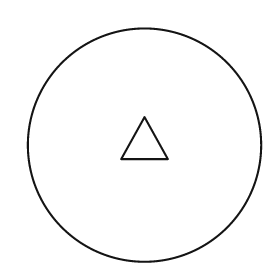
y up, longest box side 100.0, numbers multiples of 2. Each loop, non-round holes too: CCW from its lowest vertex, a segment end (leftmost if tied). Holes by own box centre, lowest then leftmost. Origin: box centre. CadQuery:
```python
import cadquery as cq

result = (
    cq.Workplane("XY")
    .moveTo(0.0, 0.0)
    .circle(50.0)
    .moveTo(-10.0, -6.0)
    .lineTo(10.0, -6.0)
    .lineTo(0.0, 12.0)
    .close()
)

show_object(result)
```